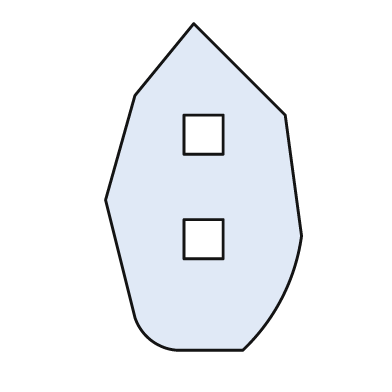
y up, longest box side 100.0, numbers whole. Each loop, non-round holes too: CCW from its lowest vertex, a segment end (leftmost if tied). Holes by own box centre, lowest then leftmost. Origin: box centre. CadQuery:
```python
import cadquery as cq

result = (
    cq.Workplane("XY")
    .moveTo(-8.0, -50.0)
    .lineTo(12.0, -50.0)
    .threePointArc((24.0, -34.0), (30.0, -15.0))
    .lineTo(25.0, 22.0)
    .lineTo(-3.0, 50.0)
    .lineTo(-21.0, 28.0)
    .lineTo(-30.0, -4.0)
    .lineTo(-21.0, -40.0)
    .threePointArc((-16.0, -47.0), (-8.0, -50.0))
    .close()
    .moveTo(-6.0, -22.0)
    .lineTo(6.0, -22.0)
    .lineTo(6.0, -10.0)
    .lineTo(-6.0, -10.0)
    .close()
    .moveTo(-6.0, 10.0)
    .lineTo(6.0, 10.0)
    .lineTo(6.0, 22.0)
    .lineTo(-6.0, 22.0)
    .close()
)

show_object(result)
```